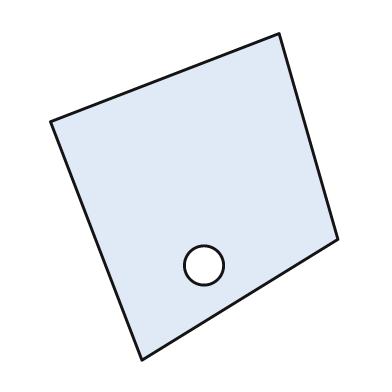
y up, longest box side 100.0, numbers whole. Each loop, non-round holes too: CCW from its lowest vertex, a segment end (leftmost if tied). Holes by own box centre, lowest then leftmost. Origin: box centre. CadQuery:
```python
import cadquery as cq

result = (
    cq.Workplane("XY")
    .moveTo(-16.0, -50.0)
    .lineTo(44.0, -13.0)
    .lineTo(26.0, 50.0)
    .lineTo(-44.0, 23.0)
    .close()
    .moveTo(3.0, -21.0)
    .circle(6.0)
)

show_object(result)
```